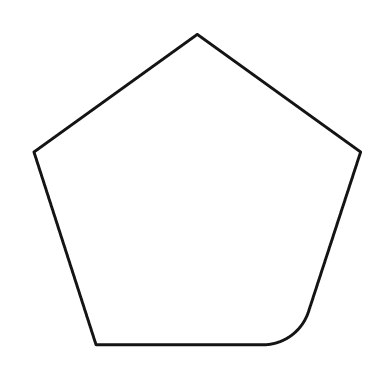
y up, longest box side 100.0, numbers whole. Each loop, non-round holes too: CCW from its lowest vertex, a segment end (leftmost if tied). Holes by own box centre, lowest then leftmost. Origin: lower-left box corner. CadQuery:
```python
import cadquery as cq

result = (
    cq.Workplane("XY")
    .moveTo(19.0, 0.0)
    .lineTo(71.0, 0.0)
    .threePointArc((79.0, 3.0), (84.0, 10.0))
    .lineTo(100.0, 59.0)
    .lineTo(50.0, 95.0)
    .lineTo(0.0, 59.0)
    .close()
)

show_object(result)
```